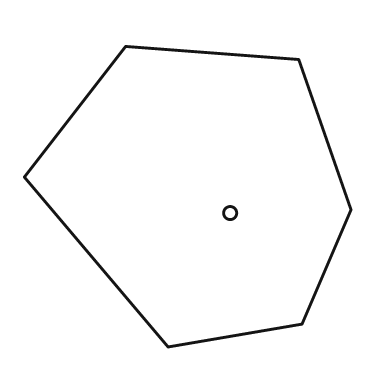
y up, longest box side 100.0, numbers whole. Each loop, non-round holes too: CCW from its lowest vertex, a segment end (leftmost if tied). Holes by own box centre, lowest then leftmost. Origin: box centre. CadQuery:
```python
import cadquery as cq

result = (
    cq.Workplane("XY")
    .moveTo(-6.0, -46.0)
    .lineTo(35.0, -39.0)
    .lineTo(50.0, -4.0)
    .lineTo(34.0, 42.0)
    .lineTo(-19.0, 46.0)
    .lineTo(-50.0, 6.0)
    .close()
    .moveTo(13.0, -5.0)
    .circle(2.0)
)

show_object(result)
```